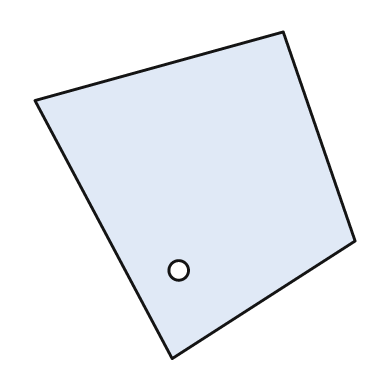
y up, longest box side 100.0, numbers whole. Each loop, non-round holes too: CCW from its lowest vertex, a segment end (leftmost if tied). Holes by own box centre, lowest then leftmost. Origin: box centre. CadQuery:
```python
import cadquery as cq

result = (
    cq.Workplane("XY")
    .moveTo(-7.0, -50.0)
    .lineTo(49.0, -14.0)
    .lineTo(27.0, 50.0)
    .lineTo(-49.0, 29.0)
    .close()
    .moveTo(-5.0, -23.0)
    .circle(3.0)
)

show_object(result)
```